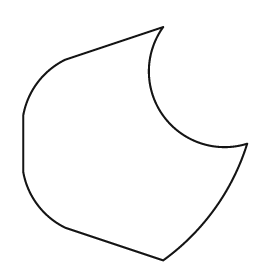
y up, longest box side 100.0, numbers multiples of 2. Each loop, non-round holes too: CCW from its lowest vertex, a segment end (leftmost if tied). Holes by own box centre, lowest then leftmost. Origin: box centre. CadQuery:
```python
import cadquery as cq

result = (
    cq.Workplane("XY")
    .moveTo(12.0, -50.0)
    .threePointArc((34.0, -28.0), (48.0, 0.0))
    .threePointArc((12.0, 12.0), (12.0, 50.0))
    .lineTo(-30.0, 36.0)
    .threePointArc((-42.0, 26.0), (-48.0, 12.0))
    .lineTo(-48.0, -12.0)
    .threePointArc((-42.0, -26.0), (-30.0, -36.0))
    .close()
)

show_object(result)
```